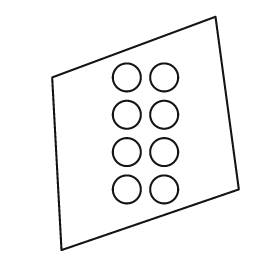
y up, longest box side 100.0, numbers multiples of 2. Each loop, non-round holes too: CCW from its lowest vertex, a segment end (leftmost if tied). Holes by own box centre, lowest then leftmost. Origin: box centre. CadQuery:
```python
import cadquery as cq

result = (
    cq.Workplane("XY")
    .moveTo(-36.0, -50.0)
    .lineTo(40.0, -24.0)
    .lineTo(30.0, 50.0)
    .lineTo(-40.0, 24.0)
    .close()
    .moveTo(-8.0, -24.0)
    .circle(6.0)
    .moveTo(8.0, -24.0)
    .circle(6.0)
    .moveTo(-8.0, -8.0)
    .circle(6.0)
    .moveTo(8.0, -8.0)
    .circle(6.0)
    .moveTo(-8.0, 8.0)
    .circle(6.0)
    .moveTo(8.0, 8.0)
    .circle(6.0)
    .moveTo(-8.0, 24.0)
    .circle(6.0)
    .moveTo(8.0, 24.0)
    .circle(6.0)
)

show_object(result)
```